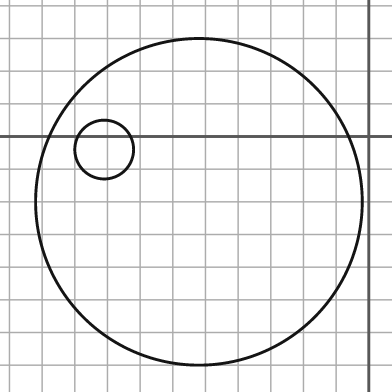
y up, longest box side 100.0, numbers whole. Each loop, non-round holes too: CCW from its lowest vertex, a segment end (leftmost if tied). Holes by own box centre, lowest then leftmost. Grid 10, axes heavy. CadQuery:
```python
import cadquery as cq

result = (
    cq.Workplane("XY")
    .moveTo(-52.0, -20.0)
    .circle(50.0)
    .moveTo(-81.0, -4.0)
    .circle(9.0)
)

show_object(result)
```